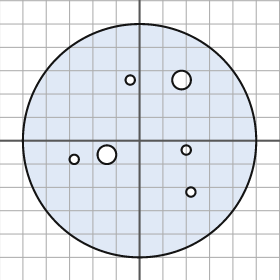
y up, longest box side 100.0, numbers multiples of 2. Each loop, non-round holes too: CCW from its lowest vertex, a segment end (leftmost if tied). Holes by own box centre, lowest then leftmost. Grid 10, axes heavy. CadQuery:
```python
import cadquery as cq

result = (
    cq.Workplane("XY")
    .moveTo(0.0, 0.0)
    .circle(50.0)
    .moveTo(22.0, -22.0)
    .circle(2.0)
    .moveTo(-28.0, -8.0)
    .circle(2.0)
    .moveTo(-14.0, -6.0)
    .circle(4.0)
    .moveTo(20.0, -4.0)
    .circle(2.0)
    .moveTo(-4.0, 26.0)
    .circle(2.0)
    .moveTo(18.0, 26.0)
    .circle(4.0)
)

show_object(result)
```